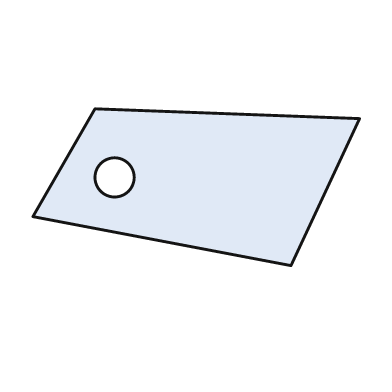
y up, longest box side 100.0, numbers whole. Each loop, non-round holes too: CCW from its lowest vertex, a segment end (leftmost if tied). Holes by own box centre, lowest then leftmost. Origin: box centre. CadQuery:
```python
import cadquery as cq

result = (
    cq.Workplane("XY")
    .moveTo(29.0, -24.0)
    .lineTo(50.0, 21.0)
    .lineTo(-31.0, 24.0)
    .lineTo(-50.0, -9.0)
    .close()
    .moveTo(-25.0, 3.0)
    .circle(6.0)
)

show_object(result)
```